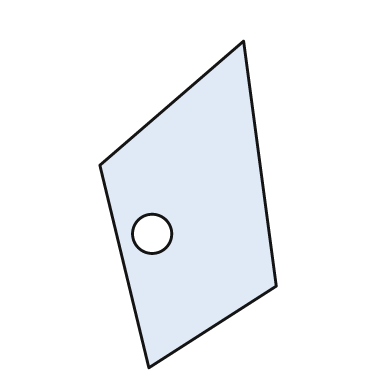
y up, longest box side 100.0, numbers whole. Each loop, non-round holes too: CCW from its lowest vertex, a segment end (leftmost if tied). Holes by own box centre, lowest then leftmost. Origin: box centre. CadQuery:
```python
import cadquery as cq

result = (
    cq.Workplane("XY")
    .moveTo(-12.0, -50.0)
    .lineTo(27.0, -25.0)
    .lineTo(17.0, 50.0)
    .lineTo(-27.0, 12.0)
    .close()
    .moveTo(-11.0, -9.0)
    .circle(6.0)
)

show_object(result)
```